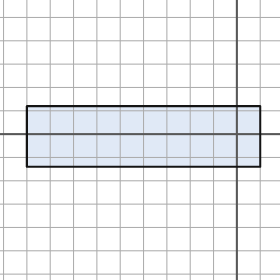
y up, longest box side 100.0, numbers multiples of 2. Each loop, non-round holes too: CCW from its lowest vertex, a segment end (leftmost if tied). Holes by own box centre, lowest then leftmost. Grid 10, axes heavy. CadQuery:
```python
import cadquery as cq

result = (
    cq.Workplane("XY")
    .moveTo(-90.0, -14.0)
    .lineTo(10.0, -14.0)
    .lineTo(10.0, 12.0)
    .lineTo(-90.0, 12.0)
    .close()
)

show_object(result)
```